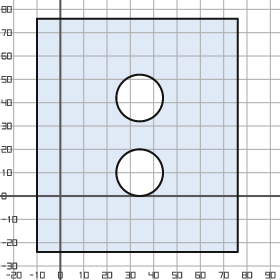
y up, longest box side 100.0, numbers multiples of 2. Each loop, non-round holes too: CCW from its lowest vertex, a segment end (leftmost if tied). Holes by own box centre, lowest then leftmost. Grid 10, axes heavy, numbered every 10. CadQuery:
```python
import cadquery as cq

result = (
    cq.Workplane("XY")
    .moveTo(-10.0, -24.0)
    .lineTo(76.0, -24.0)
    .lineTo(76.0, 76.0)
    .lineTo(-10.0, 76.0)
    .close()
    .moveTo(34.0, 10.0)
    .circle(10.0)
    .moveTo(34.0, 42.0)
    .circle(10.0)
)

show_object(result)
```